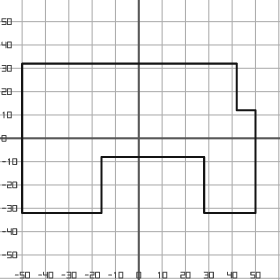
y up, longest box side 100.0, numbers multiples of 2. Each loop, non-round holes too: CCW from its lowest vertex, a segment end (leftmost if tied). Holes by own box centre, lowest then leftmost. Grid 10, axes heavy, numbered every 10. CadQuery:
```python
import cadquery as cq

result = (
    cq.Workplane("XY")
    .moveTo(-50.0, -32.0)
    .lineTo(-16.0, -32.0)
    .lineTo(-16.0, -8.0)
    .lineTo(28.0, -8.0)
    .lineTo(28.0, -32.0)
    .lineTo(50.0, -32.0)
    .lineTo(50.0, 12.0)
    .lineTo(42.0, 12.0)
    .lineTo(42.0, 32.0)
    .lineTo(-50.0, 32.0)
    .close()
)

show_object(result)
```